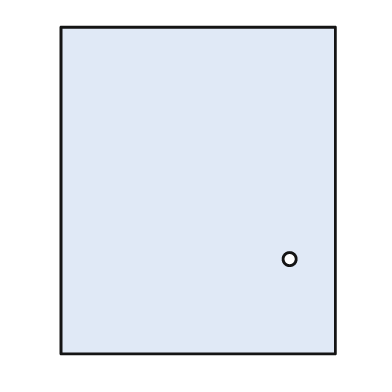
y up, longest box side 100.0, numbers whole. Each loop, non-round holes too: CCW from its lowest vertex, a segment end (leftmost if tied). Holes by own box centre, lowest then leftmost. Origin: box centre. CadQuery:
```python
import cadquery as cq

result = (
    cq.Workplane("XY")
    .moveTo(-42.0, -50.0)
    .lineTo(42.0, -50.0)
    .lineTo(42.0, 50.0)
    .lineTo(-42.0, 50.0)
    .close()
    .moveTo(28.0, -21.0)
    .circle(2.0)
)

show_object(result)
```